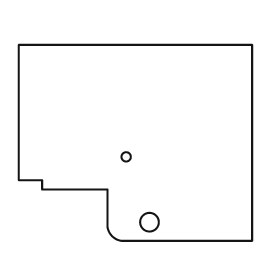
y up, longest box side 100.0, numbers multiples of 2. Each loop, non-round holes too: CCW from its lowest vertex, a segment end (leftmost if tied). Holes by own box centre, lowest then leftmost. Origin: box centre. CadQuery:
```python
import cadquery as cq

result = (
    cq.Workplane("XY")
    .moveTo(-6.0, -42.0)
    .lineTo(50.0, -42.0)
    .lineTo(50.0, 42.0)
    .lineTo(-50.0, 42.0)
    .lineTo(-50.0, -16.0)
    .lineTo(-40.0, -16.0)
    .lineTo(-40.0, -20.0)
    .lineTo(-12.0, -20.0)
    .lineTo(-12.0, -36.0)
    .threePointArc((-10.0, -40.0), (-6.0, -42.0))
    .close()
    .moveTo(6.0, -34.0)
    .circle(4.0)
    .moveTo(-4.0, -6.0)
    .circle(2.0)
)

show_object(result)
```